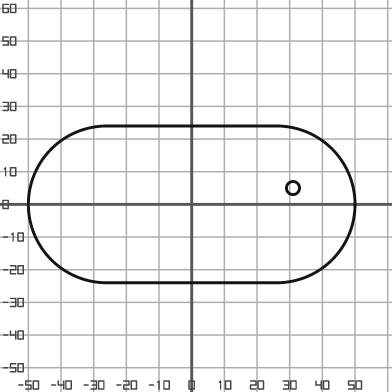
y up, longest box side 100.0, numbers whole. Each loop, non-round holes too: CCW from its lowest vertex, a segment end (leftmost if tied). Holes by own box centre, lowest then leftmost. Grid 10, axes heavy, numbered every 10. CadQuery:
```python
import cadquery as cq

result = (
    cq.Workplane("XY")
    .moveTo(-26.0, -24.0)
    .lineTo(26.0, -24.0)
    .threePointArc((50.0, 0.0), (26.0, 24.0))
    .lineTo(-26.0, 24.0)
    .threePointArc((-50.0, 0.0), (-26.0, -24.0))
    .close()
    .moveTo(31.0, 5.0)
    .circle(2.0)
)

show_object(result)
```